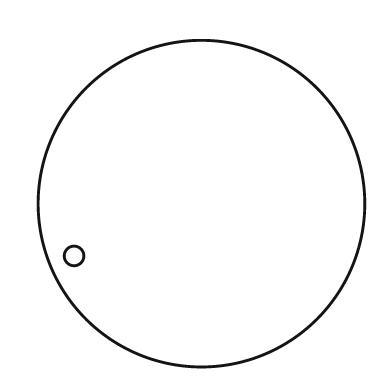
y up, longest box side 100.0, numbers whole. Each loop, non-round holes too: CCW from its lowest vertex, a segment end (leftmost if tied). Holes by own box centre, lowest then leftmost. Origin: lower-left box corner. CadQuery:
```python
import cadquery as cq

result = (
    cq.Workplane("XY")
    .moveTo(50.0, 50.0)
    .circle(50.0)
    .moveTo(11.0, 34.0)
    .circle(3.0)
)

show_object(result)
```